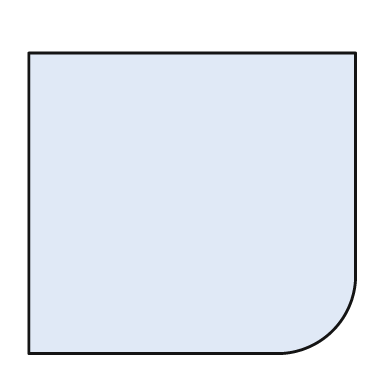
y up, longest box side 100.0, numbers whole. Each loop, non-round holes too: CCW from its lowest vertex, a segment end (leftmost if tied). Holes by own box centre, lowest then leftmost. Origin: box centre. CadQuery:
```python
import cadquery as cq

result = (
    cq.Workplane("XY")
    .moveTo(-50.0, -46.0)
    .lineTo(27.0, -46.0)
    .threePointArc((43.0, -39.0), (50.0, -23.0))
    .lineTo(50.0, 46.0)
    .lineTo(-50.0, 46.0)
    .close()
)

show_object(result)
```